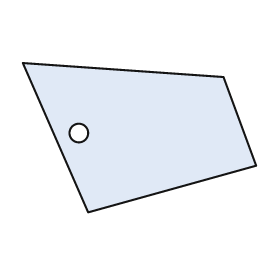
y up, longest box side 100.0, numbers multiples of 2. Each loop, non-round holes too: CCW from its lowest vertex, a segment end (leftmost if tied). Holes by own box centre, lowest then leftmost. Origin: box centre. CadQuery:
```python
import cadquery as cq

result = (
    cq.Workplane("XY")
    .moveTo(-22.0, -32.0)
    .lineTo(50.0, -12.0)
    .lineTo(36.0, 26.0)
    .lineTo(-50.0, 32.0)
    .close()
    .moveTo(-26.0, 2.0)
    .circle(4.0)
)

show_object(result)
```